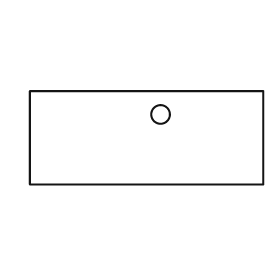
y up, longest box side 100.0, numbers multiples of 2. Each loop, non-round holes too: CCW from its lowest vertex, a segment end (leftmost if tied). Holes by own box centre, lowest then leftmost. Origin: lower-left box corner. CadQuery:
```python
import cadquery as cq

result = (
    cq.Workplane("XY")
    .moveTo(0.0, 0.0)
    .lineTo(100.0, 0.0)
    .lineTo(100.0, 40.0)
    .lineTo(0.0, 40.0)
    .close()
    .moveTo(56.0, 30.0)
    .circle(4.0)
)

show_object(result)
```